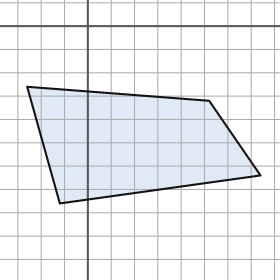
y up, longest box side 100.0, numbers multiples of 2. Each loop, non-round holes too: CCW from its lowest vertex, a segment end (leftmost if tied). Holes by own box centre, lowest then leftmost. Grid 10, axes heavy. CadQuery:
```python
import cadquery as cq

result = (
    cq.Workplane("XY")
    .moveTo(-12.0, -76.0)
    .lineTo(74.0, -64.0)
    .lineTo(52.0, -32.0)
    .lineTo(-26.0, -26.0)
    .close()
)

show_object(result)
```